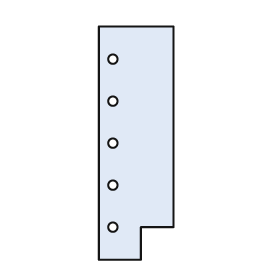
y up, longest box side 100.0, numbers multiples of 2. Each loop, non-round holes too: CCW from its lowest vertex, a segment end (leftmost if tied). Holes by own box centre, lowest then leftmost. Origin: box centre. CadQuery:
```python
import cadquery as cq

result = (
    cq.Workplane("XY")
    .moveTo(-16.0, -50.0)
    .lineTo(2.0, -50.0)
    .lineTo(2.0, -36.0)
    .lineTo(16.0, -36.0)
    .lineTo(16.0, 50.0)
    .lineTo(-16.0, 50.0)
    .close()
    .moveTo(-10.0, -36.0)
    .circle(2.0)
    .moveTo(-10.0, -18.0)
    .circle(2.0)
    .moveTo(-10.0, 0.0)
    .circle(2.0)
    .moveTo(-10.0, 18.0)
    .circle(2.0)
    .moveTo(-10.0, 36.0)
    .circle(2.0)
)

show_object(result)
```